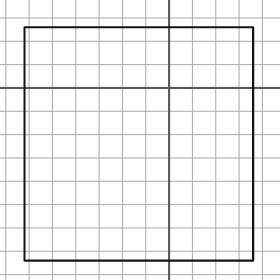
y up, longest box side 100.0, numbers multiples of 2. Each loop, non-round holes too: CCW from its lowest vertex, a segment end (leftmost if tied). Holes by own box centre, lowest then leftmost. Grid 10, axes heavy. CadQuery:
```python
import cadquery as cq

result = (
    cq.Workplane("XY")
    .moveTo(-62.0, -74.0)
    .lineTo(36.0, -74.0)
    .lineTo(36.0, 26.0)
    .lineTo(-62.0, 26.0)
    .close()
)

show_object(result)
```